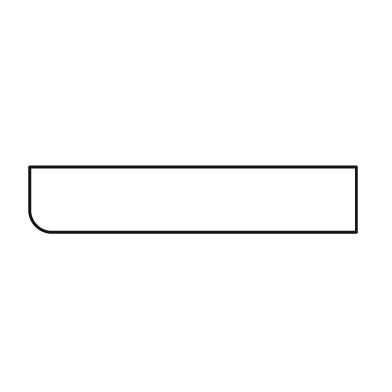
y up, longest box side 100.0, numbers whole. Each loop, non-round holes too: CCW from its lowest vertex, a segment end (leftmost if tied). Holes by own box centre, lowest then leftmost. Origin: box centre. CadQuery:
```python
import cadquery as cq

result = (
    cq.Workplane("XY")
    .moveTo(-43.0, -10.0)
    .lineTo(50.0, -10.0)
    .lineTo(50.0, 10.0)
    .lineTo(-50.0, 10.0)
    .lineTo(-50.0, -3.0)
    .threePointArc((-48.0, -8.0), (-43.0, -10.0))
    .close()
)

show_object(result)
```